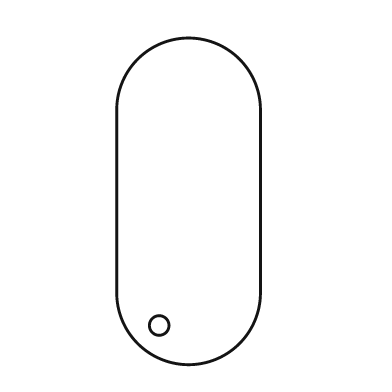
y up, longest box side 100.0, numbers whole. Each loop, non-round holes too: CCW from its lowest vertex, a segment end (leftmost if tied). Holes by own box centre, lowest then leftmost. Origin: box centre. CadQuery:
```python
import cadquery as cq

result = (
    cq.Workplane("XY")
    .moveTo(-22.0, -28.0)
    .threePointArc((0.0, -50.0), (22.0, -28.0))
    .lineTo(22.0, 28.0)
    .threePointArc((0.0, 50.0), (-22.0, 28.0))
    .close()
    .moveTo(-9.0, -38.0)
    .circle(3.0)
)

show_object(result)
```